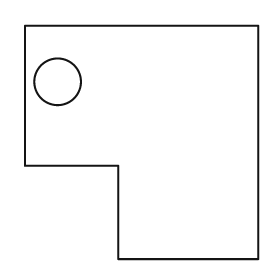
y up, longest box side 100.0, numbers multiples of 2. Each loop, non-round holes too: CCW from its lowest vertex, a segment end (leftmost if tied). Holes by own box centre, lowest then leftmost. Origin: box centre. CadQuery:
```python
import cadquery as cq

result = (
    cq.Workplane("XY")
    .moveTo(-10.0, -50.0)
    .lineTo(50.0, -50.0)
    .lineTo(50.0, 50.0)
    .lineTo(-50.0, 50.0)
    .lineTo(-50.0, -10.0)
    .lineTo(-10.0, -10.0)
    .close()
    .moveTo(-36.0, 26.0)
    .circle(10.0)
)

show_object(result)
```